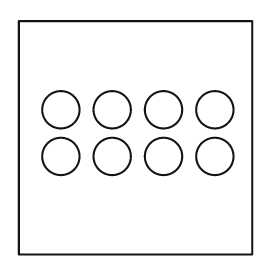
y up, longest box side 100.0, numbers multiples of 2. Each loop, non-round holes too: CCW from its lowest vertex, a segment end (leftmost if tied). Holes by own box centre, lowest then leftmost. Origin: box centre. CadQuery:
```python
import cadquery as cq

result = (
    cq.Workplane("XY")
    .moveTo(-50.0, -50.0)
    .lineTo(50.0, -50.0)
    .lineTo(50.0, 50.0)
    .lineTo(-50.0, 50.0)
    .close()
    .moveTo(-32.0, -8.0)
    .circle(8.0)
    .moveTo(-10.0, -8.0)
    .circle(8.0)
    .moveTo(12.0, -8.0)
    .circle(8.0)
    .moveTo(34.0, -8.0)
    .circle(8.0)
    .moveTo(-32.0, 12.0)
    .circle(8.0)
    .moveTo(-10.0, 12.0)
    .circle(8.0)
    .moveTo(12.0, 12.0)
    .circle(8.0)
    .moveTo(34.0, 12.0)
    .circle(8.0)
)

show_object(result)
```